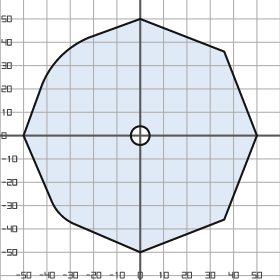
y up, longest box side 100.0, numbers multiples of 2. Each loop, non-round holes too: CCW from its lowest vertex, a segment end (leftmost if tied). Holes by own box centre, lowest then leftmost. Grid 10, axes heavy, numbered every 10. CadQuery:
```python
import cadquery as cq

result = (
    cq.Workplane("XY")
    .moveTo(0.0, -50.0)
    .lineTo(36.0, -36.0)
    .lineTo(50.0, 0.0)
    .lineTo(36.0, 36.0)
    .lineTo(0.0, 50.0)
    .lineTo(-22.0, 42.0)
    .threePointArc((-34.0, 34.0), (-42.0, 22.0))
    .lineTo(-50.0, 0.0)
    .lineTo(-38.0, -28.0)
    .threePointArc((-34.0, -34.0), (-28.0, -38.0))
    .close()
    .moveTo(0.0, 0.0)
    .circle(4.0)
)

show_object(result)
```